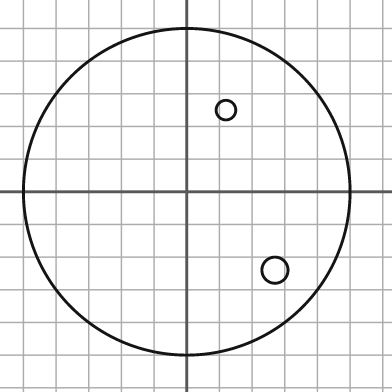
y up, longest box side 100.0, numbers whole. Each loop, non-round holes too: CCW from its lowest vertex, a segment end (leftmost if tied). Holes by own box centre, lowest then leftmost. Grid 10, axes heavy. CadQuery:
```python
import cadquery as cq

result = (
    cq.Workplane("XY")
    .moveTo(0.0, 0.0)
    .circle(50.0)
    .moveTo(27.0, -24.0)
    .circle(4.0)
    .moveTo(12.0, 25.0)
    .circle(3.0)
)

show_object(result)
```